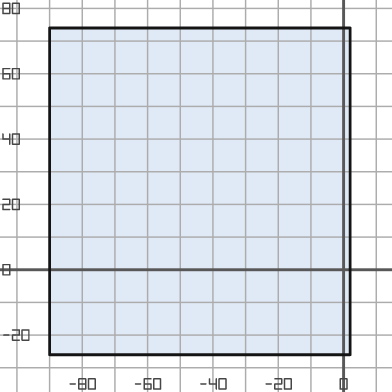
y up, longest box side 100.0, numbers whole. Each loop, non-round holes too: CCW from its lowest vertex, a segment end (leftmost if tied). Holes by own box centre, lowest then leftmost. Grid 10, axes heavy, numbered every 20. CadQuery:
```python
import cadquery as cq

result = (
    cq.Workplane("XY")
    .moveTo(-90.0, -26.0)
    .lineTo(2.0, -26.0)
    .lineTo(2.0, 74.0)
    .lineTo(-90.0, 74.0)
    .close()
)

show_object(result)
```